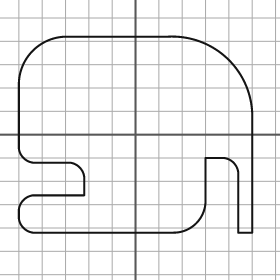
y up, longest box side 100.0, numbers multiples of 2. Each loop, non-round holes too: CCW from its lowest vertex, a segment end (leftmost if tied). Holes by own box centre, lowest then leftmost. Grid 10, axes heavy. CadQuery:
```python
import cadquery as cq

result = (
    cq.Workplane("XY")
    .moveTo(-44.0, -42.0)
    .lineTo(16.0, -42.0)
    .threePointArc((26.0, -38.0), (30.0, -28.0))
    .lineTo(30.0, -10.0)
    .lineTo(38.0, -10.0)
    .threePointArc((42.0, -12.0), (44.0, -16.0))
    .lineTo(44.0, -42.0)
    .lineTo(50.0, -42.0)
    .lineTo(50.0, 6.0)
    .threePointArc((40.0, 32.0), (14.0, 42.0))
    .lineTo(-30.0, 42.0)
    .threePointArc((-44.0, 36.0), (-50.0, 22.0))
    .lineTo(-50.0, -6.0)
    .threePointArc((-48.0, -10.0), (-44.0, -12.0))
    .lineTo(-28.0, -12.0)
    .threePointArc((-24.0, -14.0), (-22.0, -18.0))
    .lineTo(-22.0, -26.0)
    .lineTo(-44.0, -26.0)
    .threePointArc((-48.0, -28.0), (-50.0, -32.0))
    .lineTo(-50.0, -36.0)
    .threePointArc((-48.0, -40.0), (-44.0, -42.0))
    .close()
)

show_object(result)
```